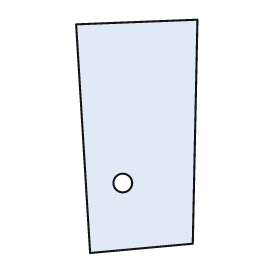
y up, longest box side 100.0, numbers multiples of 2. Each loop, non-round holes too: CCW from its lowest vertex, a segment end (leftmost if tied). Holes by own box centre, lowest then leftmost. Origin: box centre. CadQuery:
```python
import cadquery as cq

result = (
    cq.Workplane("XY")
    .moveTo(-20.0, -50.0)
    .lineTo(24.0, -46.0)
    .lineTo(26.0, 50.0)
    .lineTo(-26.0, 48.0)
    .close()
    .moveTo(-6.0, -20.0)
    .circle(4.0)
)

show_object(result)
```